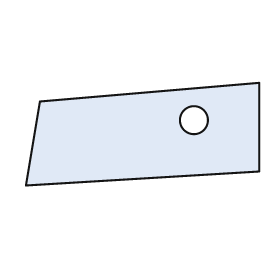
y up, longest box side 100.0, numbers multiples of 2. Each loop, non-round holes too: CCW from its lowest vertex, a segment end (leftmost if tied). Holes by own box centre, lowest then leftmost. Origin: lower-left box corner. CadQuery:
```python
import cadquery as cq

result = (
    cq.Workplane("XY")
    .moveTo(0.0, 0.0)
    .lineTo(100.0, 6.0)
    .lineTo(100.0, 44.0)
    .lineTo(6.0, 36.0)
    .close()
    .moveTo(72.0, 28.0)
    .circle(6.0)
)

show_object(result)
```